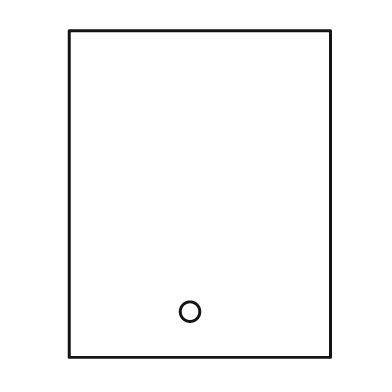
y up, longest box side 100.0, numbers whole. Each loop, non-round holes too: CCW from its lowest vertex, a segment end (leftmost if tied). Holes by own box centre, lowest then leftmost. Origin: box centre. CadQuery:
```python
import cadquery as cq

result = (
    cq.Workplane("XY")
    .moveTo(-40.0, -50.0)
    .lineTo(40.0, -50.0)
    .lineTo(40.0, 50.0)
    .lineTo(-40.0, 50.0)
    .close()
    .moveTo(-3.0, -36.0)
    .circle(3.0)
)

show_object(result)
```